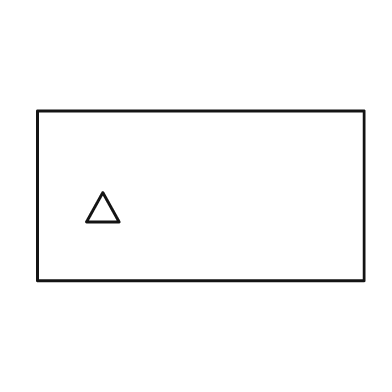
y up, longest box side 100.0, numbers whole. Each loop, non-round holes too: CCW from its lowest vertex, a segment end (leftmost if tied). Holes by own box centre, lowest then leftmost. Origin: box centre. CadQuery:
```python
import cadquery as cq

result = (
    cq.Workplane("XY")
    .moveTo(-50.0, -26.0)
    .lineTo(50.0, -26.0)
    .lineTo(50.0, 26.0)
    .lineTo(-50.0, 26.0)
    .close()
    .moveTo(-35.0, -8.0)
    .lineTo(-25.0, -8.0)
    .lineTo(-30.0, 1.0)
    .close()
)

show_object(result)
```